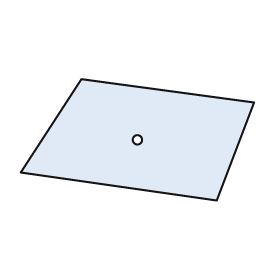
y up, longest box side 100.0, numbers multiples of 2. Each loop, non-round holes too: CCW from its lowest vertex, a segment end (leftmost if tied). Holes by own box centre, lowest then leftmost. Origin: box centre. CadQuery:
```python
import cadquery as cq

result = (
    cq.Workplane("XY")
    .moveTo(34.0, -26.0)
    .lineTo(50.0, 16.0)
    .lineTo(-24.0, 26.0)
    .lineTo(-50.0, -14.0)
    .close()
    .moveTo(0.0, 0.0)
    .circle(2.0)
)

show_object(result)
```